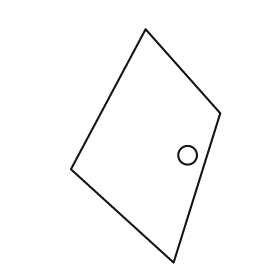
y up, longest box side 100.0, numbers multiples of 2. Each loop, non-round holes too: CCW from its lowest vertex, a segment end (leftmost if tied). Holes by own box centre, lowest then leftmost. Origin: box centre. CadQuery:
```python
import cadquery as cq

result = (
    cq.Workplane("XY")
    .moveTo(12.0, -50.0)
    .lineTo(32.0, 14.0)
    .lineTo(0.0, 50.0)
    .lineTo(-32.0, -10.0)
    .close()
    .moveTo(18.0, -4.0)
    .circle(4.0)
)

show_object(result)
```